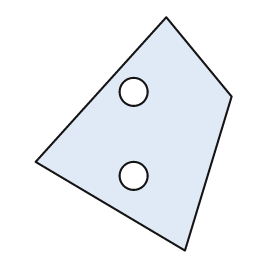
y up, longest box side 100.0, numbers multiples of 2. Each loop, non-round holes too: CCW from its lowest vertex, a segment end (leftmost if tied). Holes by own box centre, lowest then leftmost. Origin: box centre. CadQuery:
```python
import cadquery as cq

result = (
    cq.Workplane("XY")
    .moveTo(22.0, -50.0)
    .lineTo(42.0, 16.0)
    .lineTo(14.0, 50.0)
    .lineTo(-42.0, -12.0)
    .close()
    .moveTo(0.0, -18.0)
    .circle(6.0)
    .moveTo(0.0, 18.0)
    .circle(6.0)
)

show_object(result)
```